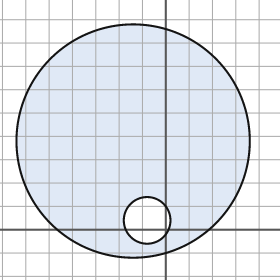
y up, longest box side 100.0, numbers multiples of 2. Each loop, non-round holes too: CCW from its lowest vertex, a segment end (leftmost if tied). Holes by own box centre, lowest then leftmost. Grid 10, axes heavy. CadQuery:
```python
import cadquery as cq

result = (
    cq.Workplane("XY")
    .moveTo(-14.0, 38.0)
    .circle(50.0)
    .moveTo(-8.0, 4.0)
    .circle(10.0)
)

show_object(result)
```